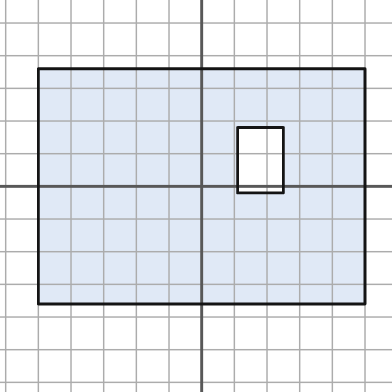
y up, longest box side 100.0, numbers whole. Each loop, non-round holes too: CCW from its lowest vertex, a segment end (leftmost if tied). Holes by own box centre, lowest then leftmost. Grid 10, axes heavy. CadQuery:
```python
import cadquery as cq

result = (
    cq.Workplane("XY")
    .moveTo(-50.0, -36.0)
    .lineTo(50.0, -36.0)
    .lineTo(50.0, 36.0)
    .lineTo(-50.0, 36.0)
    .close()
    .moveTo(11.0, -2.0)
    .lineTo(25.0, -2.0)
    .lineTo(25.0, 18.0)
    .lineTo(11.0, 18.0)
    .close()
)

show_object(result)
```